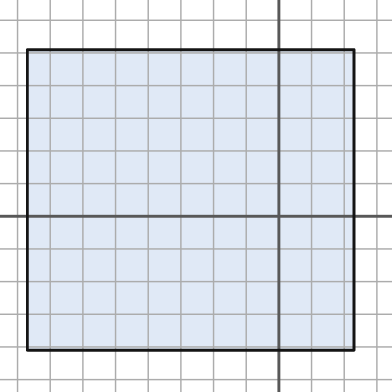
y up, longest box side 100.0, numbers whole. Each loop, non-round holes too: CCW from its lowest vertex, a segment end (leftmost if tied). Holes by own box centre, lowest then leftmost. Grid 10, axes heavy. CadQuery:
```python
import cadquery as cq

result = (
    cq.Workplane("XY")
    .moveTo(-77.0, -41.0)
    .lineTo(23.0, -41.0)
    .lineTo(23.0, 51.0)
    .lineTo(-77.0, 51.0)
    .close()
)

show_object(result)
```